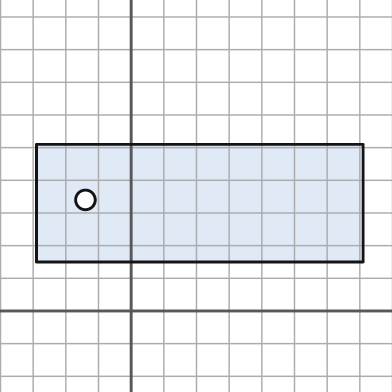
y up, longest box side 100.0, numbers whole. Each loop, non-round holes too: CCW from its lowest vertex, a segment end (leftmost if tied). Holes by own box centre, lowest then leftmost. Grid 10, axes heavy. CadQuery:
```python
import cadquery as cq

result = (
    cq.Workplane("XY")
    .moveTo(-29.0, 15.0)
    .lineTo(71.0, 15.0)
    .lineTo(71.0, 51.0)
    .lineTo(-29.0, 51.0)
    .close()
    .moveTo(-14.0, 34.0)
    .circle(3.0)
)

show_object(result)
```